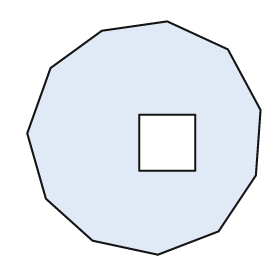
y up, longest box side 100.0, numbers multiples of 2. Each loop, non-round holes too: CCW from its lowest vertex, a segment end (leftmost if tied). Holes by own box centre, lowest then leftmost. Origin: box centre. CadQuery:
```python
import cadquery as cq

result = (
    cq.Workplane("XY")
    .moveTo(6.0, -50.0)
    .lineTo(32.0, -40.0)
    .lineTo(48.0, -16.0)
    .lineTo(50.0, 12.0)
    .lineTo(36.0, 38.0)
    .lineTo(10.0, 50.0)
    .lineTo(-18.0, 46.0)
    .lineTo(-40.0, 30.0)
    .lineTo(-50.0, 2.0)
    .lineTo(-42.0, -26.0)
    .lineTo(-22.0, -44.0)
    .close()
    .moveTo(-2.0, -14.0)
    .lineTo(22.0, -14.0)
    .lineTo(22.0, 10.0)
    .lineTo(-2.0, 10.0)
    .close()
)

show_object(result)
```